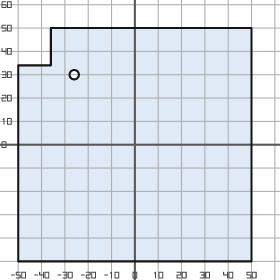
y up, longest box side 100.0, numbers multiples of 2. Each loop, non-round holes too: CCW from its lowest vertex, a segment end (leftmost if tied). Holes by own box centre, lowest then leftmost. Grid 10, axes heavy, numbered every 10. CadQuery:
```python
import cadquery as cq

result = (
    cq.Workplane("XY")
    .moveTo(-50.0, -50.0)
    .lineTo(50.0, -50.0)
    .lineTo(50.0, 50.0)
    .lineTo(-36.0, 50.0)
    .lineTo(-36.0, 34.0)
    .lineTo(-50.0, 34.0)
    .close()
    .moveTo(-26.0, 30.0)
    .circle(2.0)
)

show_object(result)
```